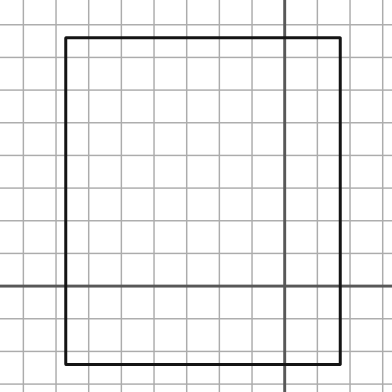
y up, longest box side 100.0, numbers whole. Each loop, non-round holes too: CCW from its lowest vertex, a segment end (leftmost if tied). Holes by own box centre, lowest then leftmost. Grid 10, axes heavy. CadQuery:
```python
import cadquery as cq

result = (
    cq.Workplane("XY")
    .moveTo(-67.0, -24.0)
    .lineTo(17.0, -24.0)
    .lineTo(17.0, 76.0)
    .lineTo(-67.0, 76.0)
    .close()
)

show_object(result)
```